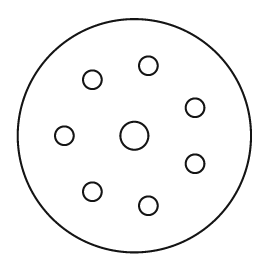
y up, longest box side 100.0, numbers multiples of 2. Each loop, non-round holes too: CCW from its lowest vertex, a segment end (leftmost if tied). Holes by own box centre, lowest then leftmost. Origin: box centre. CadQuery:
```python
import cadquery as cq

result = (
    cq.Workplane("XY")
    .moveTo(0.0, 0.0)
    .circle(50.0)
    .moveTo(6.0, -30.0)
    .circle(4.0)
    .moveTo(-18.0, -24.0)
    .circle(4.0)
    .moveTo(26.0, -12.0)
    .circle(4.0)
    .moveTo(-30.0, 0.0)
    .circle(4.0)
    .moveTo(0.0, 0.0)
    .circle(6.0)
    .moveTo(26.0, 12.0)
    .circle(4.0)
    .moveTo(-18.0, 24.0)
    .circle(4.0)
    .moveTo(6.0, 30.0)
    .circle(4.0)
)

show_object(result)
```